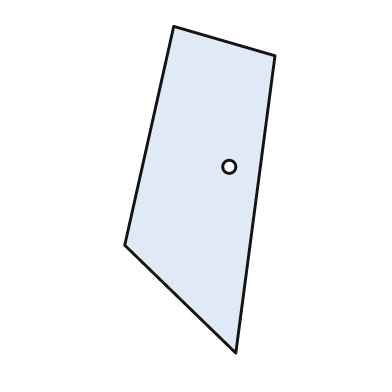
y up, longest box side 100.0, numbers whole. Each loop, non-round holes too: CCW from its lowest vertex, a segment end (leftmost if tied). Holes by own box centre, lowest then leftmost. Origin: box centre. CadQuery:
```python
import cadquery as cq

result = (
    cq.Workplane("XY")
    .moveTo(11.0, -50.0)
    .lineTo(23.0, 41.0)
    .lineTo(-8.0, 50.0)
    .lineTo(-23.0, -17.0)
    .close()
    .moveTo(9.0, 7.0)
    .circle(2.0)
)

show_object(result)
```